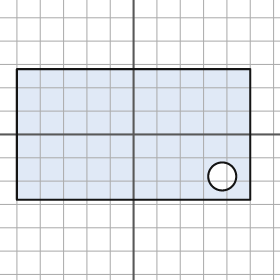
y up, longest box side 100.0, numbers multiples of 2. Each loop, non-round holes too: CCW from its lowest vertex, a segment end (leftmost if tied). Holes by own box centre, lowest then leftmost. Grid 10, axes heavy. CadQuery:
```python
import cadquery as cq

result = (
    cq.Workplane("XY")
    .moveTo(-50.0, -28.0)
    .lineTo(50.0, -28.0)
    .lineTo(50.0, 28.0)
    .lineTo(-50.0, 28.0)
    .close()
    .moveTo(38.0, -18.0)
    .circle(6.0)
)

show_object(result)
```